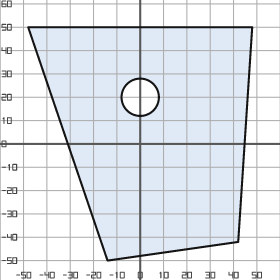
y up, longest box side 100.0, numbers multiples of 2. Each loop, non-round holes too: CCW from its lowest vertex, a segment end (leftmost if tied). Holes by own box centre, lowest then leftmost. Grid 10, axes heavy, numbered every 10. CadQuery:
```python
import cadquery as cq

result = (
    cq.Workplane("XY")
    .moveTo(-14.0, -50.0)
    .lineTo(42.0, -42.0)
    .lineTo(48.0, 50.0)
    .lineTo(-48.0, 50.0)
    .close()
    .moveTo(0.0, 20.0)
    .circle(8.0)
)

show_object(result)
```